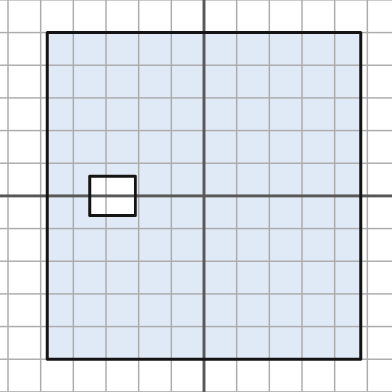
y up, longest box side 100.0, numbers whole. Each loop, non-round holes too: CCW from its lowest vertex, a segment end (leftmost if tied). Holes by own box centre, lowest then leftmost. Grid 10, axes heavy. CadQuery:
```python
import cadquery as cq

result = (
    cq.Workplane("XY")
    .moveTo(-48.0, -50.0)
    .lineTo(48.0, -50.0)
    .lineTo(48.0, 50.0)
    .lineTo(-48.0, 50.0)
    .close()
    .moveTo(-35.0, -6.0)
    .lineTo(-21.0, -6.0)
    .lineTo(-21.0, 6.0)
    .lineTo(-35.0, 6.0)
    .close()
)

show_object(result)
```